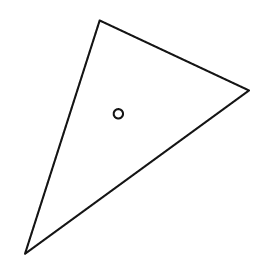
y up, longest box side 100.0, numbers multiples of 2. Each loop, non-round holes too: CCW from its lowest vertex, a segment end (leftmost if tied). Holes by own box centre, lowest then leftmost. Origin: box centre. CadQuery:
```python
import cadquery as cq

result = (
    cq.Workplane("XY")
    .moveTo(-48.0, -50.0)
    .lineTo(48.0, 20.0)
    .lineTo(-16.0, 50.0)
    .close()
    .moveTo(-8.0, 10.0)
    .circle(2.0)
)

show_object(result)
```